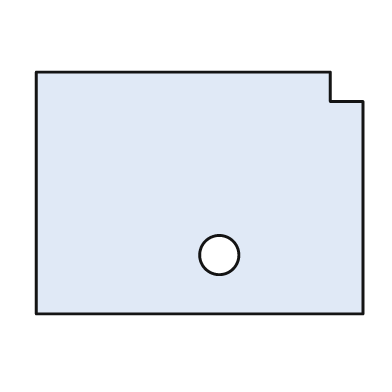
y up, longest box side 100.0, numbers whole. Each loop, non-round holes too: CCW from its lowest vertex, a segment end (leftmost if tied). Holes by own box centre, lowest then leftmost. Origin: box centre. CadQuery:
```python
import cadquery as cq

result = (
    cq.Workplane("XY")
    .moveTo(-50.0, -37.0)
    .lineTo(50.0, -37.0)
    .lineTo(50.0, 28.0)
    .lineTo(40.0, 28.0)
    .lineTo(40.0, 37.0)
    .lineTo(-50.0, 37.0)
    .close()
    .moveTo(6.0, -19.0)
    .circle(6.0)
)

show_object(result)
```